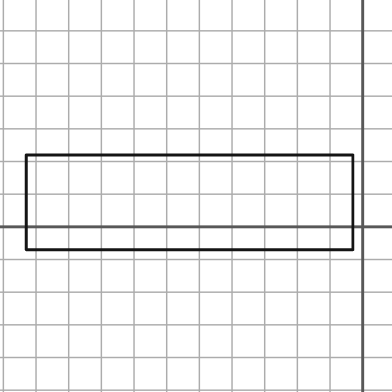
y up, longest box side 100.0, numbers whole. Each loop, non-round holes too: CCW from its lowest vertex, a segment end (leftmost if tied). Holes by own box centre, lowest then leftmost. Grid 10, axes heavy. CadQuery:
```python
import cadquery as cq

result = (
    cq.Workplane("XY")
    .moveTo(-103.0, -7.0)
    .lineTo(-3.0, -7.0)
    .lineTo(-3.0, 22.0)
    .lineTo(-103.0, 22.0)
    .close()
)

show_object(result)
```